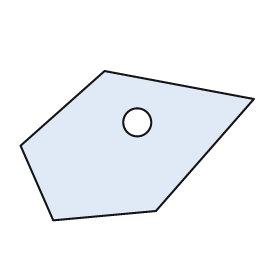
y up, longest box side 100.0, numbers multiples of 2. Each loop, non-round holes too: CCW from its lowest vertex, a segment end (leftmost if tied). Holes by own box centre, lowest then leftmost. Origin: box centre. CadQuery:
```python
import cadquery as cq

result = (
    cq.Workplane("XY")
    .moveTo(-36.0, -32.0)
    .lineTo(8.0, -28.0)
    .lineTo(50.0, 20.0)
    .lineTo(-14.0, 32.0)
    .lineTo(-50.0, 0.0)
    .close()
    .moveTo(0.0, 10.0)
    .circle(6.0)
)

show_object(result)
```